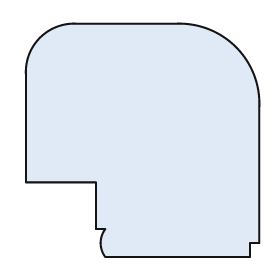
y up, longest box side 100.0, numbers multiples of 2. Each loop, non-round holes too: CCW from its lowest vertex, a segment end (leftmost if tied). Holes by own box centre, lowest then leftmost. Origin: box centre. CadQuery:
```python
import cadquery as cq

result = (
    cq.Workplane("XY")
    .moveTo(-16.0, -50.0)
    .lineTo(46.0, -50.0)
    .lineTo(46.0, -44.0)
    .lineTo(50.0, -44.0)
    .lineTo(50.0, 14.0)
    .threePointArc((40.0, 40.0), (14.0, 50.0))
    .lineTo(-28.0, 50.0)
    .threePointArc((-44.0, 44.0), (-50.0, 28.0))
    .lineTo(-50.0, -18.0)
    .lineTo(-20.0, -18.0)
    .lineTo(-20.0, -38.0)
    .lineTo(-16.0, -38.0)
    .threePointArc((-18.0, -44.0), (-16.0, -50.0))
    .close()
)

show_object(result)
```